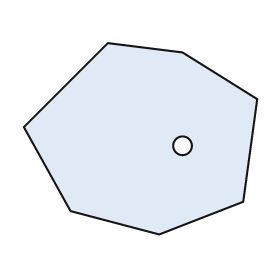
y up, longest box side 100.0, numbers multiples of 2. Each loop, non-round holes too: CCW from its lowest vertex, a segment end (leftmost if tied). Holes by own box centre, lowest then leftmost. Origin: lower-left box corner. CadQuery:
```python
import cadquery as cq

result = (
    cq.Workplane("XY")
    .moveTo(58.0, 0.0)
    .lineTo(94.0, 14.0)
    .lineTo(100.0, 58.0)
    .lineTo(68.0, 78.0)
    .lineTo(36.0, 82.0)
    .lineTo(0.0, 46.0)
    .lineTo(20.0, 10.0)
    .close()
    .moveTo(68.0, 38.0)
    .circle(4.0)
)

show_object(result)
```